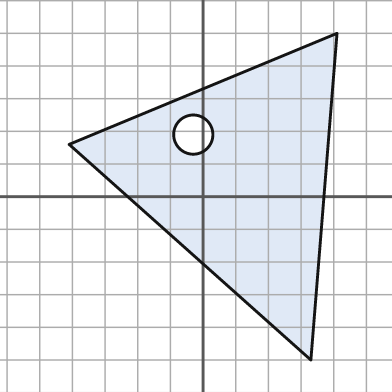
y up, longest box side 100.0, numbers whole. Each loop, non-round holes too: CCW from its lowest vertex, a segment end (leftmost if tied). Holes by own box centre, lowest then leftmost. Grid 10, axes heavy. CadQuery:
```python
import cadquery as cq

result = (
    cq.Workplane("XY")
    .moveTo(33.0, -50.0)
    .lineTo(41.0, 50.0)
    .lineTo(-41.0, 16.0)
    .close()
    .moveTo(-3.0, 19.0)
    .circle(6.0)
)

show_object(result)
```